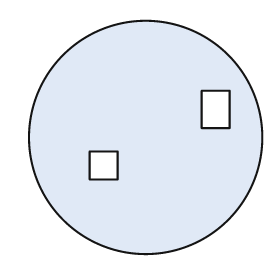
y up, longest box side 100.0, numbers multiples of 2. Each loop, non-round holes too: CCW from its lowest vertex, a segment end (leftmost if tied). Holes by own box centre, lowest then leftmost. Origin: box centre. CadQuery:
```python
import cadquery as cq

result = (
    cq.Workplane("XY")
    .moveTo(0.0, 0.0)
    .circle(50.0)
    .moveTo(-24.0, -18.0)
    .lineTo(-12.0, -18.0)
    .lineTo(-12.0, -6.0)
    .lineTo(-24.0, -6.0)
    .close()
    .moveTo(24.0, 4.0)
    .lineTo(36.0, 4.0)
    .lineTo(36.0, 20.0)
    .lineTo(24.0, 20.0)
    .close()
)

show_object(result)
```